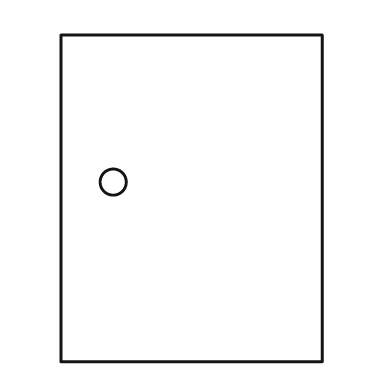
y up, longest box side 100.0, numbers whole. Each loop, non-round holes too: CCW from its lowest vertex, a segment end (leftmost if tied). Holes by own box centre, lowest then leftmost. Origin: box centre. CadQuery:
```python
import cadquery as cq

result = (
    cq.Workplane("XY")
    .moveTo(-40.0, -50.0)
    .lineTo(40.0, -50.0)
    .lineTo(40.0, 50.0)
    .lineTo(-40.0, 50.0)
    .close()
    .moveTo(-24.0, 5.0)
    .circle(4.0)
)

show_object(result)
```